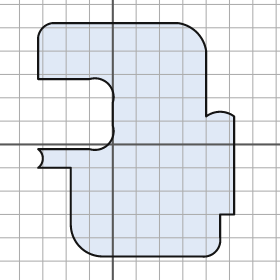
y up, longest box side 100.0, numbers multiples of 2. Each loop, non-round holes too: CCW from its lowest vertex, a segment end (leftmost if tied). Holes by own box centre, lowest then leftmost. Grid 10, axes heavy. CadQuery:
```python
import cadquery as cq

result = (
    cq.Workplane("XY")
    .moveTo(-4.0, -48.0)
    .lineTo(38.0, -48.0)
    .threePointArc((44.0, -46.0), (46.0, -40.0))
    .lineTo(46.0, -30.0)
    .lineTo(52.0, -30.0)
    .lineTo(52.0, 12.0)
    .threePointArc((46.0, 14.0), (40.0, 12.0))
    .lineTo(40.0, 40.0)
    .threePointArc((36.0, 48.0), (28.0, 52.0))
    .lineTo(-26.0, 52.0)
    .threePointArc((-30.0, 50.0), (-32.0, 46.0))
    .lineTo(-32.0, 28.0)
    .lineTo(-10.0, 28.0)
    .threePointArc((-2.0, 26.0), (0.0, 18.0))
    .lineTo(0.0, 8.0)
    .threePointArc((-2.0, 0.0), (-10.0, -2.0))
    .lineTo(-32.0, -2.0)
    .threePointArc((-30.0, -6.0), (-32.0, -10.0))
    .lineTo(-18.0, -10.0)
    .lineTo(-18.0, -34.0)
    .threePointArc((-14.0, -44.0), (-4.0, -48.0))
    .close()
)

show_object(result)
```